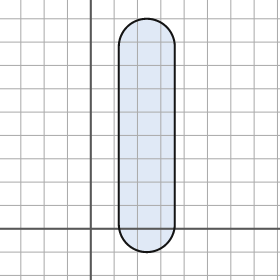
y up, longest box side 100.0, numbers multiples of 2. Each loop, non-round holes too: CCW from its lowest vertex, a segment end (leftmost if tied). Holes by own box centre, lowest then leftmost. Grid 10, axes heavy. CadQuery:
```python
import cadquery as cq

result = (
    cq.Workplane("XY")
    .moveTo(12.0, 2.0)
    .threePointArc((24.0, -10.0), (36.0, 2.0))
    .lineTo(36.0, 78.0)
    .threePointArc((24.0, 90.0), (12.0, 78.0))
    .close()
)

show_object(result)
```